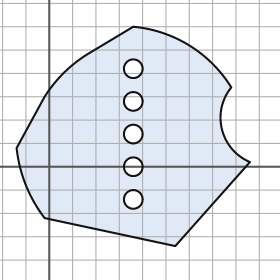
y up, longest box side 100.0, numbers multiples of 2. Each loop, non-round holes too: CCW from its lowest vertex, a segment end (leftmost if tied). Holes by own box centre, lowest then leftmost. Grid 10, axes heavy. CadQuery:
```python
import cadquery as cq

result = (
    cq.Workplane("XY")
    .moveTo(54.0, -34.0)
    .lineTo(86.0, 2.0)
    .threePointArc((74.0, 16.0), (78.0, 34.0))
    .threePointArc((60.0, 52.0), (36.0, 60.0))
    .lineTo(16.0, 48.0)
    .threePointArc((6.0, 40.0), (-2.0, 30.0))
    .lineTo(-14.0, 8.0)
    .threePointArc((-10.0, -8.0), (-2.0, -22.0))
    .close()
    .moveTo(36.0, -14.0)
    .circle(4.0)
    .moveTo(36.0, 0.0)
    .circle(4.0)
    .moveTo(36.0, 14.0)
    .circle(4.0)
    .moveTo(36.0, 28.0)
    .circle(4.0)
    .moveTo(36.0, 42.0)
    .circle(4.0)
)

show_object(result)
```